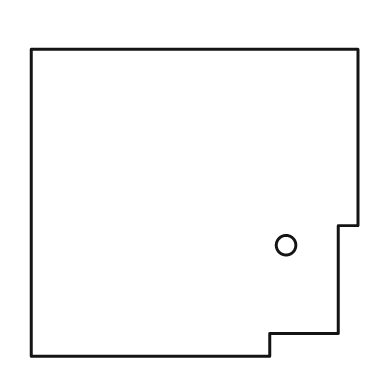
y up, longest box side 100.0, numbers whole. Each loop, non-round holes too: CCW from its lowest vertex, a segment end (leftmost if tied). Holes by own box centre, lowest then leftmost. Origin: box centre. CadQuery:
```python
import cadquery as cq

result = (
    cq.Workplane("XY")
    .moveTo(-50.0, -47.0)
    .lineTo(23.0, -47.0)
    .lineTo(23.0, -40.0)
    .lineTo(44.0, -40.0)
    .lineTo(44.0, -7.0)
    .lineTo(50.0, -7.0)
    .lineTo(50.0, 47.0)
    .lineTo(-50.0, 47.0)
    .close()
    .moveTo(28.0, -13.0)
    .circle(3.0)
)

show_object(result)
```